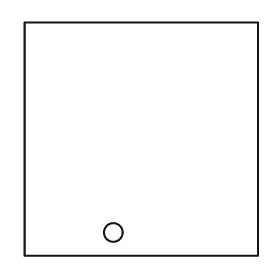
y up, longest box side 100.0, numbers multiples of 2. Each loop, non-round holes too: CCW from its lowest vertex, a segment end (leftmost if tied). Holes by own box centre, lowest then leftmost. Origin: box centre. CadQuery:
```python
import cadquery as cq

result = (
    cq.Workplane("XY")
    .moveTo(-50.0, -50.0)
    .lineTo(50.0, -50.0)
    .lineTo(50.0, 50.0)
    .lineTo(-50.0, 50.0)
    .close()
    .moveTo(-12.0, -40.0)
    .circle(4.0)
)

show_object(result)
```